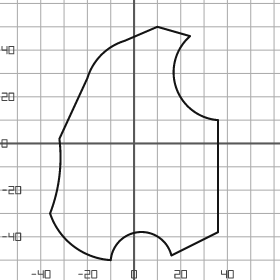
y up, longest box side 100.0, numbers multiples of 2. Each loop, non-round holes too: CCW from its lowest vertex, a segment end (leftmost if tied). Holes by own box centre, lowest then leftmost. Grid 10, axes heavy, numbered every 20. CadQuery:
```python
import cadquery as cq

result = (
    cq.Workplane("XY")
    .moveTo(-10.0, -50.0)
    .threePointArc((2.0, -38.0), (16.0, -48.0))
    .lineTo(36.0, -38.0)
    .lineTo(36.0, 10.0)
    .threePointArc((18.0, 24.0), (24.0, 46.0))
    .lineTo(10.0, 50.0)
    .lineTo(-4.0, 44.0)
    .threePointArc((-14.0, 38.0), (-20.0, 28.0))
    .lineTo(-32.0, 2.0)
    .threePointArc((-32.0, -14.0), (-36.0, -30.0))
    .threePointArc((-26.0, -44.0), (-10.0, -50.0))
    .close()
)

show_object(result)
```